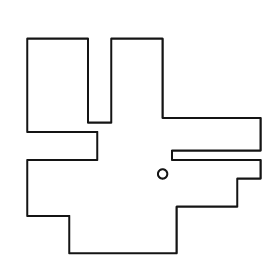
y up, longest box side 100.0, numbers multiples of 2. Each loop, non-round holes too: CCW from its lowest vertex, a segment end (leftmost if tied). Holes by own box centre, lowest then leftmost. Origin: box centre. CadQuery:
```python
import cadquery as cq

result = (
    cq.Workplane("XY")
    .moveTo(-32.0, -46.0)
    .lineTo(14.0, -46.0)
    .lineTo(14.0, -26.0)
    .lineTo(40.0, -26.0)
    .lineTo(40.0, -14.0)
    .lineTo(50.0, -14.0)
    .lineTo(50.0, -6.0)
    .lineTo(12.0, -6.0)
    .lineTo(12.0, -2.0)
    .lineTo(50.0, -2.0)
    .lineTo(50.0, 12.0)
    .lineTo(8.0, 12.0)
    .lineTo(8.0, 46.0)
    .lineTo(-14.0, 46.0)
    .lineTo(-14.0, 10.0)
    .lineTo(-24.0, 10.0)
    .lineTo(-24.0, 46.0)
    .lineTo(-50.0, 46.0)
    .lineTo(-50.0, 6.0)
    .lineTo(-20.0, 6.0)
    .lineTo(-20.0, -6.0)
    .lineTo(-50.0, -6.0)
    .lineTo(-50.0, -30.0)
    .lineTo(-32.0, -30.0)
    .close()
    .moveTo(8.0, -12.0)
    .circle(2.0)
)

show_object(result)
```